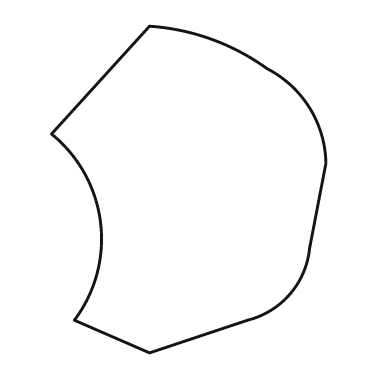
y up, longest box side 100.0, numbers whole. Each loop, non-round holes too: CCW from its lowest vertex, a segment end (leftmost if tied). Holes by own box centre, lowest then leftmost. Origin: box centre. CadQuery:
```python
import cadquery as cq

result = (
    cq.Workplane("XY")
    .moveTo(-12.0, -50.0)
    .lineTo(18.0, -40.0)
    .threePointArc((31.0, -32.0), (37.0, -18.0))
    .lineTo(42.0, 8.0)
    .threePointArc((37.0, 25.0), (24.0, 37.0))
    .threePointArc((7.0, 46.0), (-12.0, 50.0))
    .lineTo(-42.0, 17.0)
    .threePointArc((-27.0, -10.0), (-35.0, -40.0))
    .close()
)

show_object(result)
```